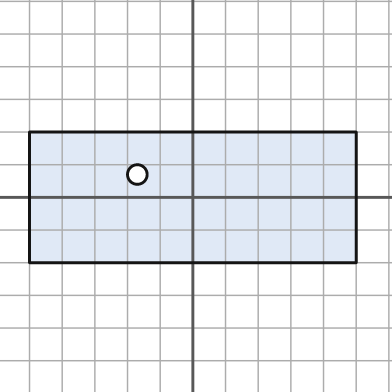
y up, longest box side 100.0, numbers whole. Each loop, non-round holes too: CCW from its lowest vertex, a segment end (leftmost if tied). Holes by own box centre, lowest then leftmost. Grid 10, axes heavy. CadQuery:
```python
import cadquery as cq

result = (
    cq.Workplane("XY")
    .moveTo(-50.0, -20.0)
    .lineTo(50.0, -20.0)
    .lineTo(50.0, 20.0)
    .lineTo(-50.0, 20.0)
    .close()
    .moveTo(-17.0, 7.0)
    .circle(3.0)
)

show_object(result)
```